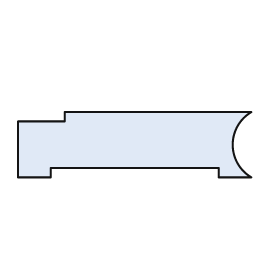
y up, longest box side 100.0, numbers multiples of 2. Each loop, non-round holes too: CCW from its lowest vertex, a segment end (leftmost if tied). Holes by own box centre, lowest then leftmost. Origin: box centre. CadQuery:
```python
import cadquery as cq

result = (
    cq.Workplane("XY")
    .moveTo(-50.0, -14.0)
    .lineTo(-36.0, -14.0)
    .lineTo(-36.0, -10.0)
    .lineTo(36.0, -10.0)
    .lineTo(36.0, -14.0)
    .lineTo(50.0, -14.0)
    .threePointArc((42.0, 0.0), (50.0, 14.0))
    .lineTo(-30.0, 14.0)
    .lineTo(-30.0, 10.0)
    .lineTo(-50.0, 10.0)
    .close()
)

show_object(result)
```